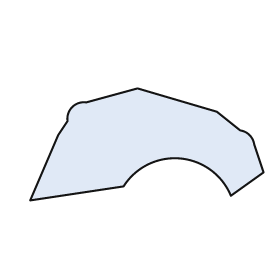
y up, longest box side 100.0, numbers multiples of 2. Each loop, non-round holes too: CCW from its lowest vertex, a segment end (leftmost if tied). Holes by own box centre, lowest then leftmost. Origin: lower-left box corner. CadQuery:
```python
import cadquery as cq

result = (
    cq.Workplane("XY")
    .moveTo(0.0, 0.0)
    .lineTo(40.0, 6.0)
    .threePointArc((64.0, 18.0), (86.0, 2.0))
    .lineTo(100.0, 12.0)
    .lineTo(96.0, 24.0)
    .threePointArc((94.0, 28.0), (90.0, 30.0))
    .lineTo(80.0, 38.0)
    .lineTo(46.0, 48.0)
    .lineTo(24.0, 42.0)
    .threePointArc((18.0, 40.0), (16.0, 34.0))
    .lineTo(12.0, 28.0)
    .close()
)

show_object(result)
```